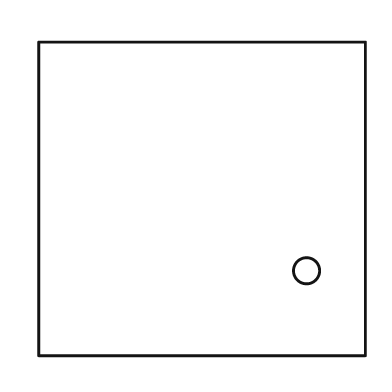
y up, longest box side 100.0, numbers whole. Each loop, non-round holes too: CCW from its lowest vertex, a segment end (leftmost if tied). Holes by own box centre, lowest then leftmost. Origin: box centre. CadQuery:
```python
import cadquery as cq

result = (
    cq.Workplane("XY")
    .moveTo(-50.0, -48.0)
    .lineTo(50.0, -48.0)
    .lineTo(50.0, 48.0)
    .lineTo(-50.0, 48.0)
    .close()
    .moveTo(32.0, -22.0)
    .circle(4.0)
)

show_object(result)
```